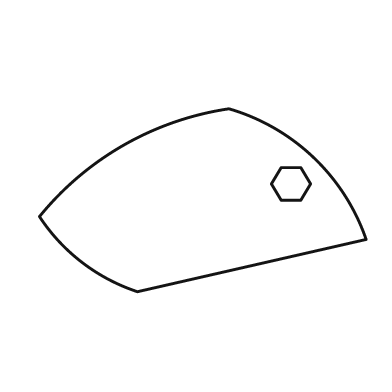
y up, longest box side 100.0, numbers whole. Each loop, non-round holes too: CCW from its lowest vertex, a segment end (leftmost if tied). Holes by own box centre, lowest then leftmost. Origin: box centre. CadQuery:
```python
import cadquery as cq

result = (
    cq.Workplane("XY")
    .moveTo(-20.0, -28.0)
    .lineTo(50.0, -12.0)
    .threePointArc((34.0, 13.0), (8.0, 28.0))
    .threePointArc((-24.0, 17.0), (-50.0, -5.0))
    .threePointArc((-37.0, -19.0), (-20.0, -28.0))
    .close()
    .moveTo(24.0, 0.0)
    .lineTo(30.0, 0.0)
    .lineTo(33.0, 5.0)
    .lineTo(30.0, 10.0)
    .lineTo(24.0, 10.0)
    .lineTo(21.0, 5.0)
    .close()
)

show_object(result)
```